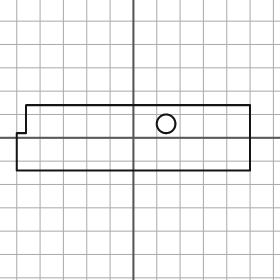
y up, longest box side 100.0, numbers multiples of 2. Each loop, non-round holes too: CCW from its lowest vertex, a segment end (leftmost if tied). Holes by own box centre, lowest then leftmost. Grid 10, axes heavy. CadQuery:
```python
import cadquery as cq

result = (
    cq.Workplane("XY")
    .moveTo(-50.0, -14.0)
    .lineTo(50.0, -14.0)
    .lineTo(50.0, 14.0)
    .lineTo(-46.0, 14.0)
    .lineTo(-46.0, 2.0)
    .lineTo(-50.0, 2.0)
    .close()
    .moveTo(14.0, 6.0)
    .circle(4.0)
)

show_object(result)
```